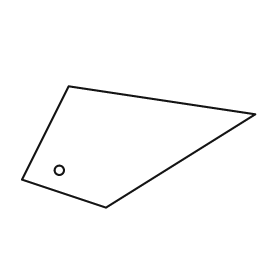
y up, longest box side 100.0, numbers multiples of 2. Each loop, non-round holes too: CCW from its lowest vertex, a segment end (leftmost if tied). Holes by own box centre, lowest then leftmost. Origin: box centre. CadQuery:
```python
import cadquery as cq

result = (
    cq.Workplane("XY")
    .moveTo(-14.0, -26.0)
    .lineTo(50.0, 14.0)
    .lineTo(-30.0, 26.0)
    .lineTo(-50.0, -14.0)
    .close()
    .moveTo(-34.0, -10.0)
    .circle(2.0)
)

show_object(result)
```